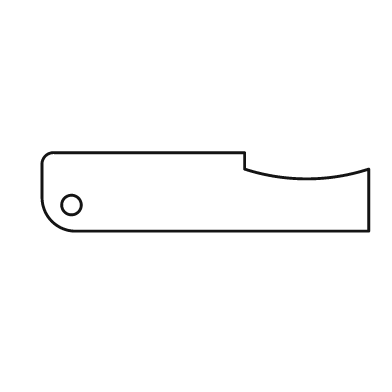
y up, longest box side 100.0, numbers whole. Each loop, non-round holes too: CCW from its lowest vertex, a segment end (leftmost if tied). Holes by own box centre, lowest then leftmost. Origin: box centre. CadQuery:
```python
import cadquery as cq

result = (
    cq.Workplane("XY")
    .moveTo(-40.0, -12.0)
    .lineTo(50.0, -12.0)
    .lineTo(50.0, 7.0)
    .threePointArc((31.0, 4.0), (12.0, 7.0))
    .lineTo(12.0, 12.0)
    .lineTo(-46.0, 12.0)
    .threePointArc((-49.0, 11.0), (-50.0, 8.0))
    .lineTo(-50.0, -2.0)
    .threePointArc((-47.0, -9.0), (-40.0, -12.0))
    .close()
    .moveTo(-41.0, -4.0)
    .circle(3.0)
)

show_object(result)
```